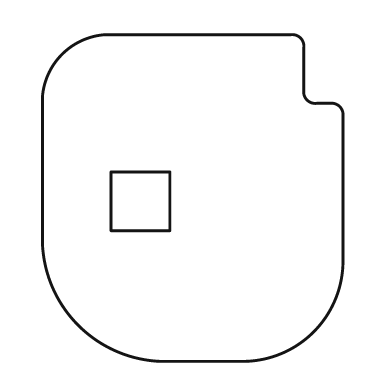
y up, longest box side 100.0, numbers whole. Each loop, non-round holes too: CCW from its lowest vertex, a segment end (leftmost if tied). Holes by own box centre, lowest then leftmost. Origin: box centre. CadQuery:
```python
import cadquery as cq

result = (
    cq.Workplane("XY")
    .moveTo(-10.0, -50.0)
    .lineTo(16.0, -50.0)
    .threePointArc((37.0, -41.0), (46.0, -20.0))
    .lineTo(46.0, 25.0)
    .threePointArc((45.0, 28.0), (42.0, 29.0))
    .lineTo(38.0, 29.0)
    .threePointArc((35.0, 30.0), (34.0, 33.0))
    .lineTo(34.0, 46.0)
    .threePointArc((33.0, 49.0), (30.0, 50.0))
    .lineTo(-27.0, 50.0)
    .threePointArc((-40.0, 44.0), (-46.0, 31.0))
    .lineTo(-46.0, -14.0)
    .threePointArc((-35.0, -39.0), (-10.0, -50.0))
    .close()
    .moveTo(-25.0, -10.0)
    .lineTo(-7.0, -10.0)
    .lineTo(-7.0, 8.0)
    .lineTo(-25.0, 8.0)
    .close()
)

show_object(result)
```